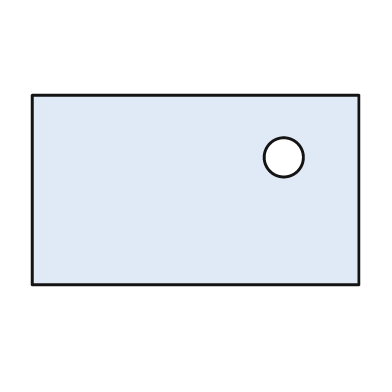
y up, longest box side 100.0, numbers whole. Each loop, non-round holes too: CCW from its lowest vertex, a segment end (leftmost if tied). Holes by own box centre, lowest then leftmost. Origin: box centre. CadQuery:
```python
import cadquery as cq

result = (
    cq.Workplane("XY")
    .moveTo(-50.0, -29.0)
    .lineTo(50.0, -29.0)
    .lineTo(50.0, 29.0)
    .lineTo(-50.0, 29.0)
    .close()
    .moveTo(27.0, 10.0)
    .circle(6.0)
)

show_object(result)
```